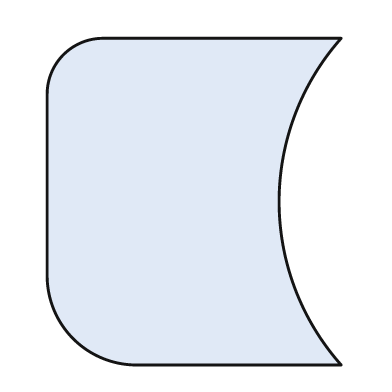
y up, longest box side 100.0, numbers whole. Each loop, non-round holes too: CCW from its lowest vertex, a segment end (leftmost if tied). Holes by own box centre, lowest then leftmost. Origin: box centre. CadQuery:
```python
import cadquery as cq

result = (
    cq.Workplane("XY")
    .moveTo(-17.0, -50.0)
    .lineTo(45.0, -50.0)
    .threePointArc((26.0, 0.0), (45.0, 50.0))
    .lineTo(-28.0, 50.0)
    .threePointArc((-40.0, 45.0), (-45.0, 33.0))
    .lineTo(-45.0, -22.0)
    .threePointArc((-37.0, -42.0), (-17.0, -50.0))
    .close()
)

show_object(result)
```